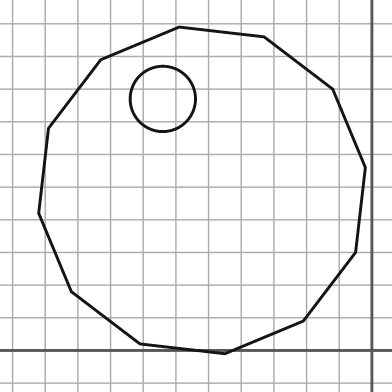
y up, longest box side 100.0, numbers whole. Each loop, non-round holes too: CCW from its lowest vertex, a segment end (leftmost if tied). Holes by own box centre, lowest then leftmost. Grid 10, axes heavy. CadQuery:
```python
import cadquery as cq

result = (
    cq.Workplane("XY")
    .moveTo(-45.0, -1.0)
    .lineTo(-21.0, 9.0)
    .lineTo(-5.0, 30.0)
    .lineTo(-2.0, 56.0)
    .lineTo(-12.0, 80.0)
    .lineTo(-33.0, 96.0)
    .lineTo(-59.0, 99.0)
    .lineTo(-83.0, 89.0)
    .lineTo(-99.0, 68.0)
    .lineTo(-102.0, 42.0)
    .lineTo(-92.0, 18.0)
    .lineTo(-71.0, 2.0)
    .close()
    .moveTo(-64.0, 77.0)
    .circle(10.0)
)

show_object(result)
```